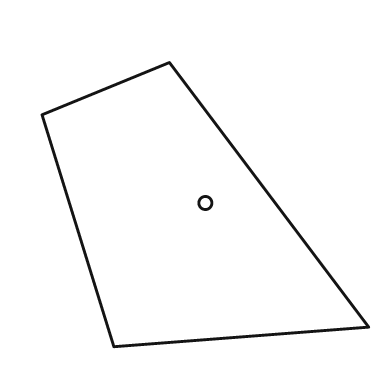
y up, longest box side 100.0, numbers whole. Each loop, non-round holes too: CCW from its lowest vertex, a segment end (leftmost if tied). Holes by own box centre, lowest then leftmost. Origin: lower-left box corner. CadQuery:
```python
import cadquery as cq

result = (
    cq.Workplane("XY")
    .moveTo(22.0, 0.0)
    .lineTo(100.0, 6.0)
    .lineTo(39.0, 87.0)
    .lineTo(0.0, 71.0)
    .close()
    .moveTo(50.0, 44.0)
    .circle(2.0)
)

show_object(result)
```